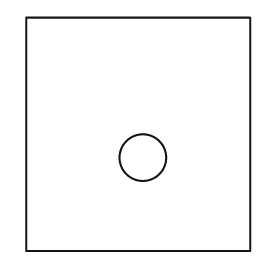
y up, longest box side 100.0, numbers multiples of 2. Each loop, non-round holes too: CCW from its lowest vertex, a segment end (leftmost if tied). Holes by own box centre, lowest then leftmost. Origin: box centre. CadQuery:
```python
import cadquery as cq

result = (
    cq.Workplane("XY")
    .moveTo(-48.0, -50.0)
    .lineTo(48.0, -50.0)
    .lineTo(48.0, 50.0)
    .lineTo(-48.0, 50.0)
    .close()
    .moveTo(2.0, -10.0)
    .circle(10.0)
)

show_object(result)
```